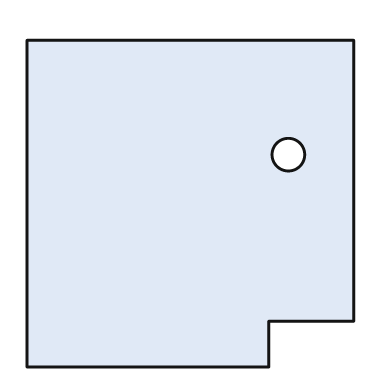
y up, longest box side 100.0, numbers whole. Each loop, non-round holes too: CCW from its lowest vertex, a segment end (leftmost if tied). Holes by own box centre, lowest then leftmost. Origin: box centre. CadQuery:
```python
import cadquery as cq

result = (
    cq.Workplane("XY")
    .moveTo(-50.0, -50.0)
    .lineTo(24.0, -50.0)
    .lineTo(24.0, -36.0)
    .lineTo(50.0, -36.0)
    .lineTo(50.0, 50.0)
    .lineTo(-50.0, 50.0)
    .close()
    .moveTo(30.0, 15.0)
    .circle(5.0)
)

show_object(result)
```